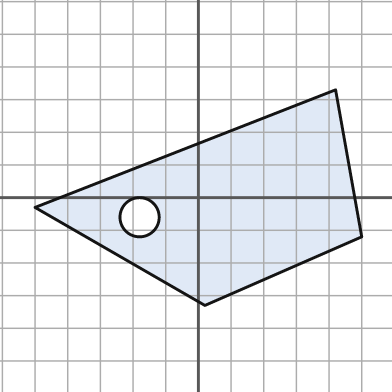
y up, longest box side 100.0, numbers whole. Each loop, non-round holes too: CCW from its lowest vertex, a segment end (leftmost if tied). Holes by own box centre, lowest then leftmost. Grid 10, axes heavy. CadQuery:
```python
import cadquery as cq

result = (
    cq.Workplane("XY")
    .moveTo(2.0, -33.0)
    .lineTo(50.0, -12.0)
    .lineTo(42.0, 33.0)
    .lineTo(-50.0, -3.0)
    .close()
    .moveTo(-18.0, -6.0)
    .circle(6.0)
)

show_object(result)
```